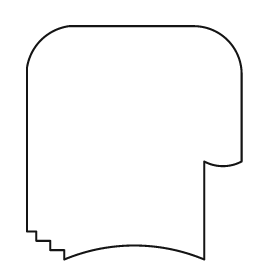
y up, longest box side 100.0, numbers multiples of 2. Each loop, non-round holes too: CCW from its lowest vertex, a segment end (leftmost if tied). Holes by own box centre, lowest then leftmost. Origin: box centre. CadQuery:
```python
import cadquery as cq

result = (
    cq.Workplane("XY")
    .moveTo(-30.0, -50.0)
    .threePointArc((0.0, -44.0), (30.0, -50.0))
    .lineTo(30.0, -8.0)
    .threePointArc((38.0, -10.0), (46.0, -8.0))
    .lineTo(46.0, 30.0)
    .threePointArc((40.0, 44.0), (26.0, 50.0))
    .lineTo(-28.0, 50.0)
    .threePointArc((-40.0, 44.0), (-46.0, 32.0))
    .lineTo(-46.0, -38.0)
    .lineTo(-42.0, -38.0)
    .lineTo(-42.0, -42.0)
    .lineTo(-36.0, -42.0)
    .lineTo(-36.0, -46.0)
    .lineTo(-30.0, -46.0)
    .close()
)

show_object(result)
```